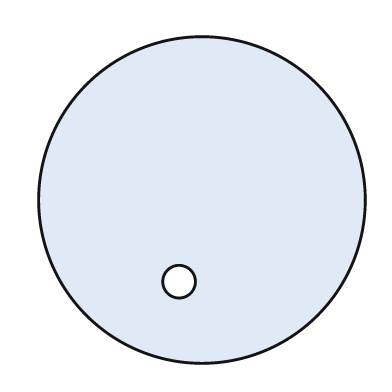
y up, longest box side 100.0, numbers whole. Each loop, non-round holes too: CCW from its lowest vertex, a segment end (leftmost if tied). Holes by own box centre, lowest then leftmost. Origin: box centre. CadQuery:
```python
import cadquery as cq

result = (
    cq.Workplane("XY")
    .moveTo(0.0, 0.0)
    .circle(50.0)
    .moveTo(-7.0, -25.0)
    .circle(5.0)
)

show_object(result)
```